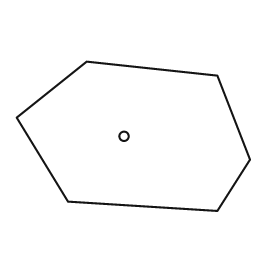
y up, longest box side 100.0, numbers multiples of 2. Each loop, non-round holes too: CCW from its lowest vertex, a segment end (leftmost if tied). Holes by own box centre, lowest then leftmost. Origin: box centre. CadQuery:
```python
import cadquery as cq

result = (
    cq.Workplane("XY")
    .moveTo(36.0, -32.0)
    .lineTo(50.0, -10.0)
    .lineTo(36.0, 26.0)
    .lineTo(-20.0, 32.0)
    .lineTo(-50.0, 8.0)
    .lineTo(-28.0, -28.0)
    .close()
    .moveTo(-4.0, 0.0)
    .circle(2.0)
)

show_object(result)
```